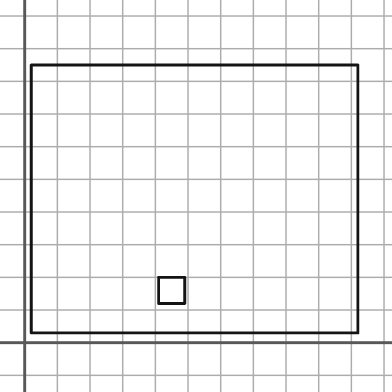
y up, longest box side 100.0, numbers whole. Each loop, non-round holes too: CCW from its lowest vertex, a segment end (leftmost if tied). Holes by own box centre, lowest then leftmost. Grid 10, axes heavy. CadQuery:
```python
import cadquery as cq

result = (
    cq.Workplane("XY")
    .moveTo(2.0, 3.0)
    .lineTo(102.0, 3.0)
    .lineTo(102.0, 85.0)
    .lineTo(2.0, 85.0)
    .close()
    .moveTo(41.0, 12.0)
    .lineTo(49.0, 12.0)
    .lineTo(49.0, 20.0)
    .lineTo(41.0, 20.0)
    .close()
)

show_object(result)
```